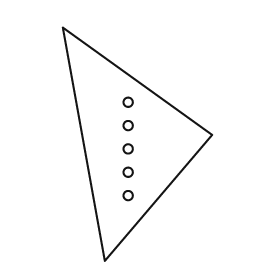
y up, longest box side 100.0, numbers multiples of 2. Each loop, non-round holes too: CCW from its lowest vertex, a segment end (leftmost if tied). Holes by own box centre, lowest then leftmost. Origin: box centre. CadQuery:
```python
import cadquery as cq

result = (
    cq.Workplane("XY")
    .moveTo(-14.0, -50.0)
    .lineTo(32.0, 4.0)
    .lineTo(-32.0, 50.0)
    .close()
    .moveTo(-4.0, -22.0)
    .circle(2.0)
    .moveTo(-4.0, -12.0)
    .circle(2.0)
    .moveTo(-4.0, -2.0)
    .circle(2.0)
    .moveTo(-4.0, 8.0)
    .circle(2.0)
    .moveTo(-4.0, 18.0)
    .circle(2.0)
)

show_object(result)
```